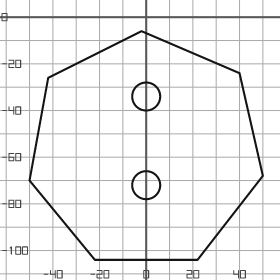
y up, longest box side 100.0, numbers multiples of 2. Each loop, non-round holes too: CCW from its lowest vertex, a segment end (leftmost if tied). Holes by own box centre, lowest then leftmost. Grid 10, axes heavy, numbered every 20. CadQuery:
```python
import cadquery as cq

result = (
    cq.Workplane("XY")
    .moveTo(-22.0, -104.0)
    .lineTo(22.0, -104.0)
    .lineTo(50.0, -68.0)
    .lineTo(40.0, -24.0)
    .lineTo(-2.0, -6.0)
    .lineTo(-42.0, -26.0)
    .lineTo(-50.0, -70.0)
    .close()
    .moveTo(0.0, -72.0)
    .circle(6.0)
    .moveTo(0.0, -34.0)
    .circle(6.0)
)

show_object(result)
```